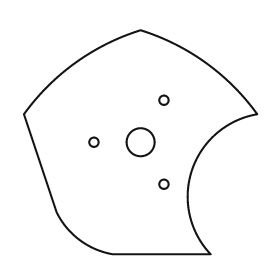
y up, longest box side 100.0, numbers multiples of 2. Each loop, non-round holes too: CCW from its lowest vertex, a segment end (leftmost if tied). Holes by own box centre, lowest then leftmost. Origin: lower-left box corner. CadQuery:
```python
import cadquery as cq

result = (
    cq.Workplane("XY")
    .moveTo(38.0, 0.0)
    .lineTo(80.0, 0.0)
    .threePointArc((72.0, 36.0), (100.0, 60.0))
    .threePointArc((78.0, 82.0), (50.0, 96.0))
    .threePointArc((22.0, 82.0), (0.0, 60.0))
    .lineTo(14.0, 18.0)
    .threePointArc((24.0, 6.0), (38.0, 0.0))
    .close()
    .moveTo(60.0, 30.0)
    .circle(2.0)
    .moveTo(30.0, 48.0)
    .circle(2.0)
    .moveTo(50.0, 48.0)
    .circle(6.0)
    .moveTo(60.0, 66.0)
    .circle(2.0)
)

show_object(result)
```